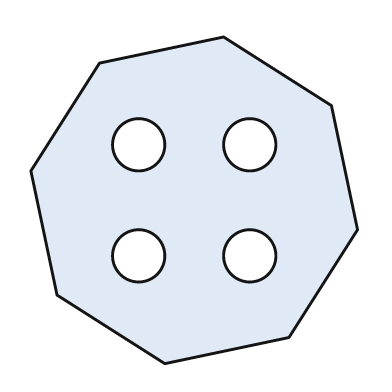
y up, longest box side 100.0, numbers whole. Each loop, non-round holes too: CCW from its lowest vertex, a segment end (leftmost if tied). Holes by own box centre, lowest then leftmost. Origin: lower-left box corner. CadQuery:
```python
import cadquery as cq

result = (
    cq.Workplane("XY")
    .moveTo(41.0, 0.0)
    .lineTo(79.0, 8.0)
    .lineTo(100.0, 41.0)
    .lineTo(92.0, 79.0)
    .lineTo(59.0, 100.0)
    .lineTo(21.0, 92.0)
    .lineTo(0.0, 59.0)
    .lineTo(8.0, 21.0)
    .close()
    .moveTo(33.0, 33.0)
    .circle(8.0)
    .moveTo(67.0, 33.0)
    .circle(8.0)
    .moveTo(33.0, 67.0)
    .circle(8.0)
    .moveTo(67.0, 67.0)
    .circle(8.0)
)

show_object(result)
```